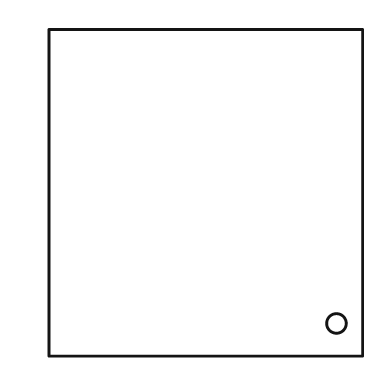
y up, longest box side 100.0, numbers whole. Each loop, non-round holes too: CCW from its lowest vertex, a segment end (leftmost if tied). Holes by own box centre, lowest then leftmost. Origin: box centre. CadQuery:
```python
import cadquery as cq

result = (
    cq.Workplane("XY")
    .moveTo(-48.0, -50.0)
    .lineTo(48.0, -50.0)
    .lineTo(48.0, 50.0)
    .lineTo(-48.0, 50.0)
    .close()
    .moveTo(40.0, -40.0)
    .circle(3.0)
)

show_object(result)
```